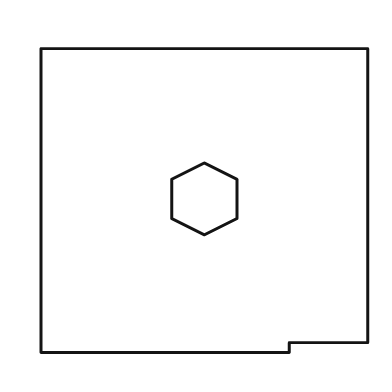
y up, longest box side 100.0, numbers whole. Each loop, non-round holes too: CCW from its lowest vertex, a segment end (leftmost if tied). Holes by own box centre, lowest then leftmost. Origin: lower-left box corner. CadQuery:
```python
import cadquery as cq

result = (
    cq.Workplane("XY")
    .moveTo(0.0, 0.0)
    .lineTo(76.0, 0.0)
    .lineTo(76.0, 3.0)
    .lineTo(100.0, 3.0)
    .lineTo(100.0, 93.0)
    .lineTo(0.0, 93.0)
    .close()
    .moveTo(50.0, 36.0)
    .lineTo(60.0, 41.0)
    .lineTo(60.0, 53.0)
    .lineTo(50.0, 58.0)
    .lineTo(40.0, 53.0)
    .lineTo(40.0, 41.0)
    .close()
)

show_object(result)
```